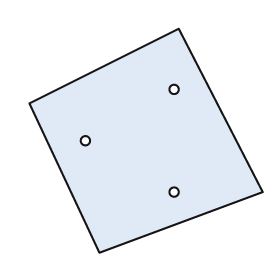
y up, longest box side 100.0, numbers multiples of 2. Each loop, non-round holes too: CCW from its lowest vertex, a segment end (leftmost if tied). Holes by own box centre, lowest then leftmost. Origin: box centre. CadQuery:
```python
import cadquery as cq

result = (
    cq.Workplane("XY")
    .moveTo(-20.0, -48.0)
    .lineTo(50.0, -22.0)
    .lineTo(14.0, 48.0)
    .lineTo(-50.0, 16.0)
    .close()
    .moveTo(12.0, -22.0)
    .circle(2.0)
    .moveTo(-26.0, 0.0)
    .circle(2.0)
    .moveTo(12.0, 22.0)
    .circle(2.0)
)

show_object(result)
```